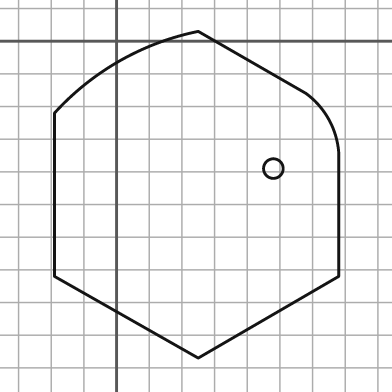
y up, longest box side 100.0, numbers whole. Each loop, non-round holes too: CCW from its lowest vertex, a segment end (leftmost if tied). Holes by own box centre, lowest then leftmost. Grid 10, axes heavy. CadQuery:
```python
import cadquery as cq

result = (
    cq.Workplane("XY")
    .moveTo(25.0, -97.0)
    .lineTo(68.0, -72.0)
    .lineTo(68.0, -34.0)
    .threePointArc((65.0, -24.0), (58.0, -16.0))
    .lineTo(25.0, 3.0)
    .threePointArc((1.0, -6.0), (-19.0, -22.0))
    .lineTo(-19.0, -72.0)
    .close()
    .moveTo(48.0, -39.0)
    .circle(3.0)
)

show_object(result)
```